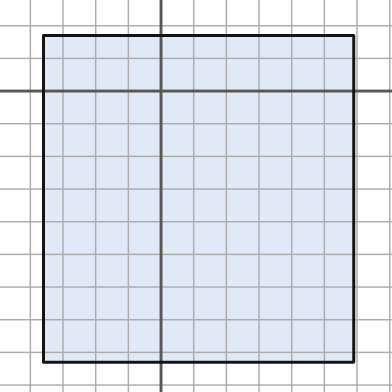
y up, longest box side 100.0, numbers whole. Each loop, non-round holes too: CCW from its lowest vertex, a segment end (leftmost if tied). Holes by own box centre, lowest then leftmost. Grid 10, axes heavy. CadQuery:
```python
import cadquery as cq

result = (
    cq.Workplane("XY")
    .moveTo(-36.0, -83.0)
    .lineTo(59.0, -83.0)
    .lineTo(59.0, 17.0)
    .lineTo(-36.0, 17.0)
    .close()
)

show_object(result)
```